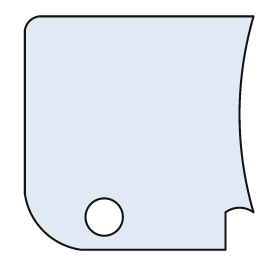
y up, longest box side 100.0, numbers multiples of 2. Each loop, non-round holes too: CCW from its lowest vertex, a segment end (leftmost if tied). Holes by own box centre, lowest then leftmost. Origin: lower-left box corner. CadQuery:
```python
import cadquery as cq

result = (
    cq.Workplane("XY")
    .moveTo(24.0, 0.0)
    .lineTo(86.0, 0.0)
    .lineTo(86.0, 16.0)
    .threePointArc((92.0, 18.0), (98.0, 16.0))
    .threePointArc((92.0, 58.0), (98.0, 100.0))
    .lineTo(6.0, 100.0)
    .threePointArc((2.0, 98.0), (0.0, 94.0))
    .lineTo(0.0, 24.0)
    .threePointArc((8.0, 8.0), (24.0, 0.0))
    .close()
    .moveTo(34.0, 14.0)
    .circle(8.0)
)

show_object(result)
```